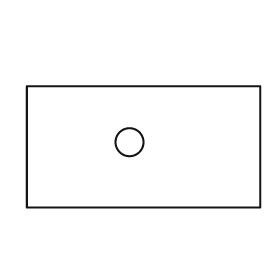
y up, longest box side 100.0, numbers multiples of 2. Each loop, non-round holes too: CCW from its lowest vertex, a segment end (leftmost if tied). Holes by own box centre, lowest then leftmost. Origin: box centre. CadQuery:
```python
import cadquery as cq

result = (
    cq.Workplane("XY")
    .moveTo(-50.0, -26.0)
    .lineTo(50.0, -26.0)
    .lineTo(50.0, 26.0)
    .lineTo(-50.0, 26.0)
    .close()
    .moveTo(-6.0, 2.0)
    .circle(6.0)
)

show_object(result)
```